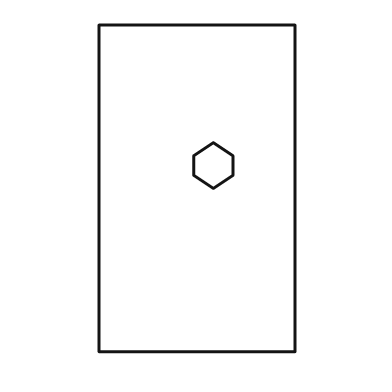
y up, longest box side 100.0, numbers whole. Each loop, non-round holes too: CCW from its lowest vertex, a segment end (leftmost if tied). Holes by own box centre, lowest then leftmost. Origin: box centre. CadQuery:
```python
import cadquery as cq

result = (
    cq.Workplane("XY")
    .moveTo(-30.0, -50.0)
    .lineTo(30.0, -50.0)
    .lineTo(30.0, 50.0)
    .lineTo(-30.0, 50.0)
    .close()
    .moveTo(5.0, 0.0)
    .lineTo(11.0, 4.0)
    .lineTo(11.0, 10.0)
    .lineTo(5.0, 14.0)
    .lineTo(-1.0, 10.0)
    .lineTo(-1.0, 4.0)
    .close()
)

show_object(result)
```